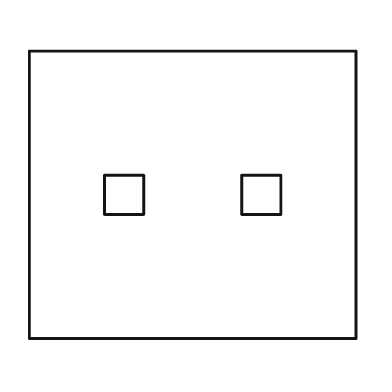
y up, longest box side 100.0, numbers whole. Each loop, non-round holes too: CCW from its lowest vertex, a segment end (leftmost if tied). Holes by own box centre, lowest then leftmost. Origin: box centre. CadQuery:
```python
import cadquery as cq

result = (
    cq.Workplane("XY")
    .moveTo(-50.0, -44.0)
    .lineTo(50.0, -44.0)
    .lineTo(50.0, 44.0)
    .lineTo(-50.0, 44.0)
    .close()
    .moveTo(-27.0, -6.0)
    .lineTo(-15.0, -6.0)
    .lineTo(-15.0, 6.0)
    .lineTo(-27.0, 6.0)
    .close()
    .moveTo(15.0, -6.0)
    .lineTo(27.0, -6.0)
    .lineTo(27.0, 6.0)
    .lineTo(15.0, 6.0)
    .close()
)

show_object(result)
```